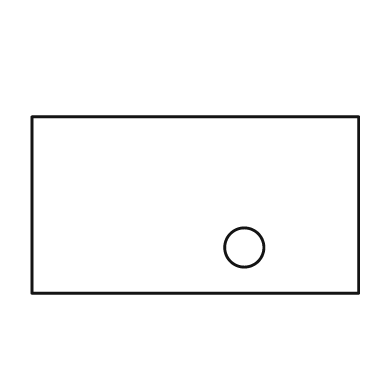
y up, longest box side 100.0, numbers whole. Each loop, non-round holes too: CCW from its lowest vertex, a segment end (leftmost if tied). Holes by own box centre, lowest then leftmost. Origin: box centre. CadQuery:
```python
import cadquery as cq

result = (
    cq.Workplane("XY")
    .moveTo(-50.0, -27.0)
    .lineTo(50.0, -27.0)
    .lineTo(50.0, 27.0)
    .lineTo(-50.0, 27.0)
    .close()
    .moveTo(15.0, -13.0)
    .circle(6.0)
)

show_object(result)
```